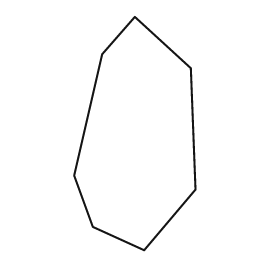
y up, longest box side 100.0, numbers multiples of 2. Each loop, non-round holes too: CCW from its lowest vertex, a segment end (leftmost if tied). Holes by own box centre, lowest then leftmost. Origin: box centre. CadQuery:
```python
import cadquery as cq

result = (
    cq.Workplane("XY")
    .moveTo(4.0, -50.0)
    .lineTo(26.0, -24.0)
    .lineTo(24.0, 28.0)
    .lineTo(0.0, 50.0)
    .lineTo(-14.0, 34.0)
    .lineTo(-26.0, -18.0)
    .lineTo(-18.0, -40.0)
    .close()
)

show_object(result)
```